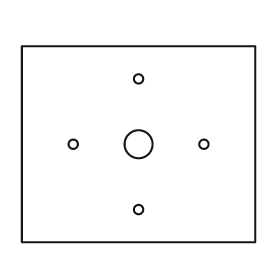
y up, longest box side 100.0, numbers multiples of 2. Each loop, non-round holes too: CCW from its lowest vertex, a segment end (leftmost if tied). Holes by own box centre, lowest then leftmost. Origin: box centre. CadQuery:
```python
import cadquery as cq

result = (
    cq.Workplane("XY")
    .moveTo(-50.0, -42.0)
    .lineTo(50.0, -42.0)
    .lineTo(50.0, 42.0)
    .lineTo(-50.0, 42.0)
    .close()
    .moveTo(0.0, -28.0)
    .circle(2.0)
    .moveTo(-28.0, 0.0)
    .circle(2.0)
    .moveTo(0.0, 0.0)
    .circle(6.0)
    .moveTo(28.0, 0.0)
    .circle(2.0)
    .moveTo(0.0, 28.0)
    .circle(2.0)
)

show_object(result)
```